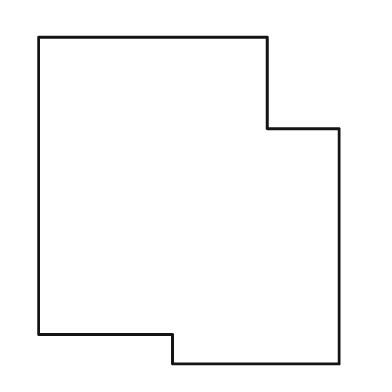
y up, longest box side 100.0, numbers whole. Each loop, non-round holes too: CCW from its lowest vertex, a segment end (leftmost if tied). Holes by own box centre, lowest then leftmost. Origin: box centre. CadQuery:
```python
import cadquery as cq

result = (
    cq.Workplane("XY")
    .moveTo(-5.0, -50.0)
    .lineTo(46.0, -50.0)
    .lineTo(46.0, 22.0)
    .lineTo(24.0, 22.0)
    .lineTo(24.0, 50.0)
    .lineTo(-46.0, 50.0)
    .lineTo(-46.0, -41.0)
    .lineTo(-5.0, -41.0)
    .close()
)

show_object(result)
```